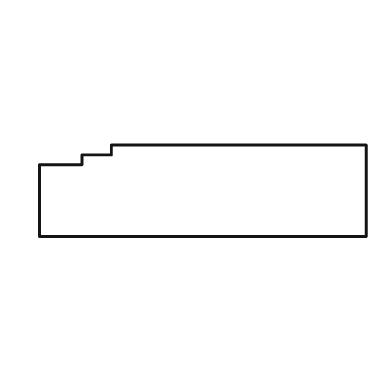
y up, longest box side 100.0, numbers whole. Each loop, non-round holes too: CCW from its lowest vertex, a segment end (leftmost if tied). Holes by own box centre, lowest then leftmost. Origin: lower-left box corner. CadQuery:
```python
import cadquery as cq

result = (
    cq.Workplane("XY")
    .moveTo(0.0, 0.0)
    .lineTo(100.0, 0.0)
    .lineTo(100.0, 28.0)
    .lineTo(22.0, 28.0)
    .lineTo(22.0, 25.0)
    .lineTo(13.0, 25.0)
    .lineTo(13.0, 22.0)
    .lineTo(0.0, 22.0)
    .close()
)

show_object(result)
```